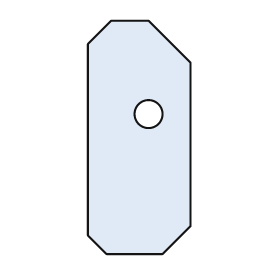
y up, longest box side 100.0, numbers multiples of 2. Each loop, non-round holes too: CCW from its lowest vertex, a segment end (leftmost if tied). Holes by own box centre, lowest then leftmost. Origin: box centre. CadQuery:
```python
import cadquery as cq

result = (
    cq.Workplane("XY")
    .moveTo(-14.0, -50.0)
    .lineTo(10.0, -50.0)
    .lineTo(22.0, -38.0)
    .lineTo(22.0, 32.0)
    .lineTo(4.0, 50.0)
    .lineTo(-12.0, 50.0)
    .lineTo(-22.0, 40.0)
    .lineTo(-22.0, -42.0)
    .close()
    .moveTo(4.0, 10.0)
    .circle(6.0)
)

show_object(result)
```